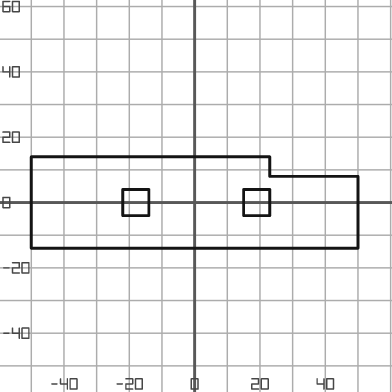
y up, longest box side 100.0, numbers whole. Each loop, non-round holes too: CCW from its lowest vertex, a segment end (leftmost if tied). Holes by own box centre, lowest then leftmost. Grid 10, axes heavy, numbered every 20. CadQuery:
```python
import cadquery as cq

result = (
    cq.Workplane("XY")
    .moveTo(-50.0, -14.0)
    .lineTo(50.0, -14.0)
    .lineTo(50.0, 8.0)
    .lineTo(23.0, 8.0)
    .lineTo(23.0, 14.0)
    .lineTo(-50.0, 14.0)
    .close()
    .moveTo(-22.0, -4.0)
    .lineTo(-14.0, -4.0)
    .lineTo(-14.0, 4.0)
    .lineTo(-22.0, 4.0)
    .close()
    .moveTo(15.0, -4.0)
    .lineTo(23.0, -4.0)
    .lineTo(23.0, 4.0)
    .lineTo(15.0, 4.0)
    .close()
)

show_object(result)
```